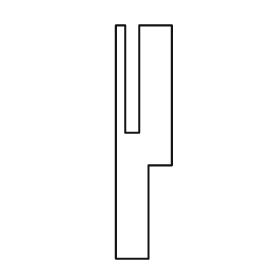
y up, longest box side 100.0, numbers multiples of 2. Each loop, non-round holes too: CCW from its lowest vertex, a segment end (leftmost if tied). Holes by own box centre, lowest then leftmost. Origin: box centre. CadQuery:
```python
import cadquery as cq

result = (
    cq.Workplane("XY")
    .moveTo(-12.0, -50.0)
    .lineTo(2.0, -50.0)
    .lineTo(2.0, -10.0)
    .lineTo(12.0, -10.0)
    .lineTo(12.0, 50.0)
    .lineTo(-2.0, 50.0)
    .lineTo(-2.0, 4.0)
    .lineTo(-8.0, 4.0)
    .lineTo(-8.0, 50.0)
    .lineTo(-12.0, 50.0)
    .close()
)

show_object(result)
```